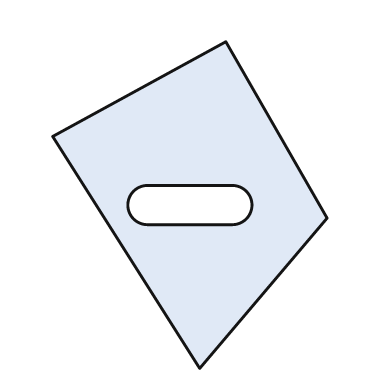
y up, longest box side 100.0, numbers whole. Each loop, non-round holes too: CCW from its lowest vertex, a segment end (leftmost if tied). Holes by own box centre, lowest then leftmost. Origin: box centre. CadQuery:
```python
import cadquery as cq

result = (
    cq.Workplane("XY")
    .moveTo(3.0, -50.0)
    .lineTo(42.0, -4.0)
    .lineTo(11.0, 50.0)
    .lineTo(-42.0, 21.0)
    .close()
    .moveTo(-13.0, -6.0)
    .lineTo(13.0, -6.0)
    .threePointArc((19.0, 0.0), (13.0, 6.0))
    .lineTo(-13.0, 6.0)
    .threePointArc((-19.0, 0.0), (-13.0, -6.0))
    .close()
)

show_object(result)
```